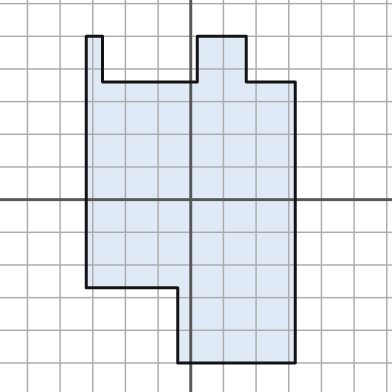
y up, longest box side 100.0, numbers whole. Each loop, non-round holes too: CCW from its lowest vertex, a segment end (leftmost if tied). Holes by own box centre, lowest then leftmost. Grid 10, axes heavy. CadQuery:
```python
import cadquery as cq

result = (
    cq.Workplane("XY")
    .moveTo(-4.0, -50.0)
    .lineTo(32.0, -50.0)
    .lineTo(32.0, 36.0)
    .lineTo(17.0, 36.0)
    .lineTo(17.0, 50.0)
    .lineTo(2.0, 50.0)
    .lineTo(2.0, 36.0)
    .lineTo(-27.0, 36.0)
    .lineTo(-27.0, 50.0)
    .lineTo(-32.0, 50.0)
    .lineTo(-32.0, -27.0)
    .lineTo(-4.0, -27.0)
    .close()
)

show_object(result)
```